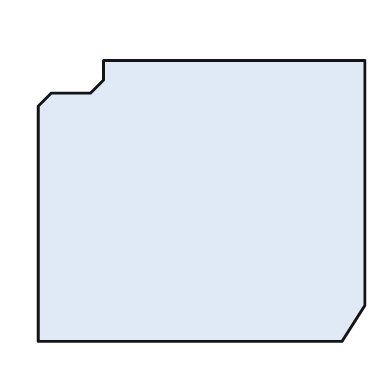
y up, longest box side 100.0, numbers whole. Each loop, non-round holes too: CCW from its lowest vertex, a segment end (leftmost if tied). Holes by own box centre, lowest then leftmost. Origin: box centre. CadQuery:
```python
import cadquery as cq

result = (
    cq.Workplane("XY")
    .moveTo(-50.0, -43.0)
    .lineTo(43.0, -43.0)
    .lineTo(50.0, -32.0)
    .lineTo(50.0, 43.0)
    .lineTo(-30.0, 43.0)
    .lineTo(-30.0, 37.0)
    .lineTo(-34.0, 33.0)
    .lineTo(-46.0, 33.0)
    .lineTo(-50.0, 29.0)
    .close()
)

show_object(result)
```